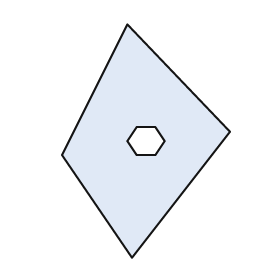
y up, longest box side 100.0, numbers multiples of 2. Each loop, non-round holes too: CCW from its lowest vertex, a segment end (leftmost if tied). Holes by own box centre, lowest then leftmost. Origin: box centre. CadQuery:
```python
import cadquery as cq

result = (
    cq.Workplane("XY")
    .moveTo(-6.0, -50.0)
    .lineTo(36.0, 4.0)
    .lineTo(-8.0, 50.0)
    .lineTo(-36.0, -6.0)
    .close()
    .moveTo(-4.0, -6.0)
    .lineTo(4.0, -6.0)
    .lineTo(8.0, 0.0)
    .lineTo(4.0, 6.0)
    .lineTo(-4.0, 6.0)
    .lineTo(-8.0, 0.0)
    .close()
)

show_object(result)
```